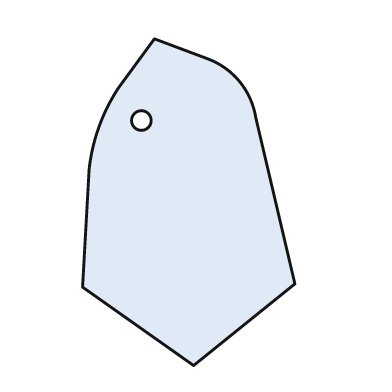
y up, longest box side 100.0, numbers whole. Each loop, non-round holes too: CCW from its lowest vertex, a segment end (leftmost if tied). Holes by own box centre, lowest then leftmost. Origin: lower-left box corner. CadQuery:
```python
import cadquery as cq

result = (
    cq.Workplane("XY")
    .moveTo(34.0, 0.0)
    .lineTo(65.0, 25.0)
    .lineTo(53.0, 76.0)
    .threePointArc((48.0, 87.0), (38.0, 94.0))
    .lineTo(22.0, 100.0)
    .lineTo(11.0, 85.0)
    .threePointArc((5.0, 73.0), (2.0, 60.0))
    .lineTo(0.0, 24.0)
    .close()
    .moveTo(18.0, 75.0)
    .circle(3.0)
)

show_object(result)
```